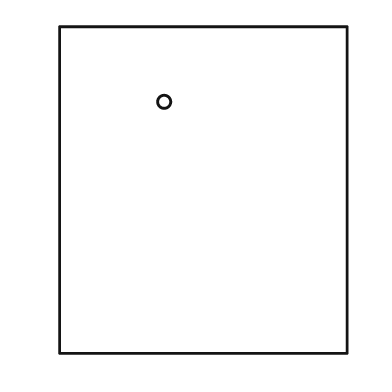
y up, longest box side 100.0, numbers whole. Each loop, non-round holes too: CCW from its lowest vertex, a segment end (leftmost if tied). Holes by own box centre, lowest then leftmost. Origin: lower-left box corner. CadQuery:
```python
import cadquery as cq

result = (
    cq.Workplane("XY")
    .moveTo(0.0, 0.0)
    .lineTo(88.0, 0.0)
    .lineTo(88.0, 100.0)
    .lineTo(0.0, 100.0)
    .close()
    .moveTo(32.0, 77.0)
    .circle(2.0)
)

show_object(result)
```